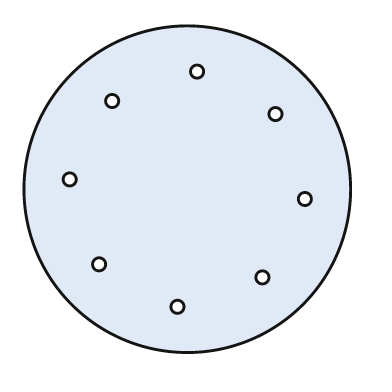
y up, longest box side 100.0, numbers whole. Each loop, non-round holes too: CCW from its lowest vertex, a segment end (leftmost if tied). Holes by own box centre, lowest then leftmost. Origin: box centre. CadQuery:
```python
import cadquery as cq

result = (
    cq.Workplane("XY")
    .moveTo(0.0, 0.0)
    .circle(50.0)
    .moveTo(-3.0, -36.0)
    .circle(2.0)
    .moveTo(23.0, -27.0)
    .circle(2.0)
    .moveTo(-27.0, -23.0)
    .circle(2.0)
    .moveTo(36.0, -3.0)
    .circle(2.0)
    .moveTo(-36.0, 3.0)
    .circle(2.0)
    .moveTo(27.0, 23.0)
    .circle(2.0)
    .moveTo(-23.0, 27.0)
    .circle(2.0)
    .moveTo(3.0, 36.0)
    .circle(2.0)
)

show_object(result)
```